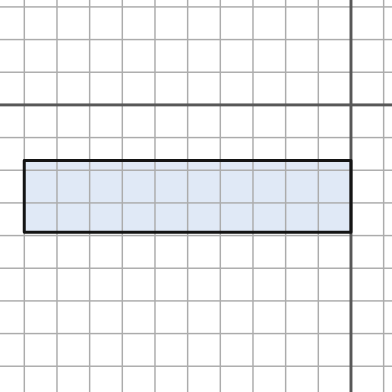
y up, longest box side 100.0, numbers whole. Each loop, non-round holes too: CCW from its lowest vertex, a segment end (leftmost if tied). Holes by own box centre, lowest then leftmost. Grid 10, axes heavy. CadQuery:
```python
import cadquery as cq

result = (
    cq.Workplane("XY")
    .moveTo(-100.0, -39.0)
    .lineTo(0.0, -39.0)
    .lineTo(0.0, -17.0)
    .lineTo(-100.0, -17.0)
    .close()
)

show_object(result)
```